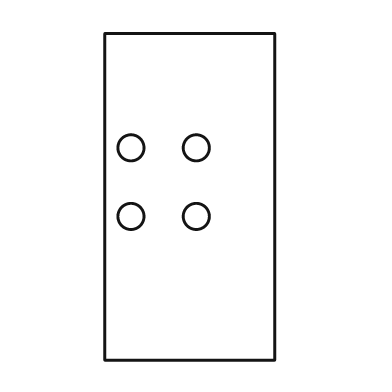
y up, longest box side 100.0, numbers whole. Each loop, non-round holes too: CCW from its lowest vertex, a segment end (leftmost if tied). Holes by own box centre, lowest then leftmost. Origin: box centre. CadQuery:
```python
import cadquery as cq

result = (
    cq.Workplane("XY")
    .moveTo(-26.0, -50.0)
    .lineTo(26.0, -50.0)
    .lineTo(26.0, 50.0)
    .lineTo(-26.0, 50.0)
    .close()
    .moveTo(-18.0, -6.0)
    .circle(4.0)
    .moveTo(2.0, -6.0)
    .circle(4.0)
    .moveTo(-18.0, 15.0)
    .circle(4.0)
    .moveTo(2.0, 15.0)
    .circle(4.0)
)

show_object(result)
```